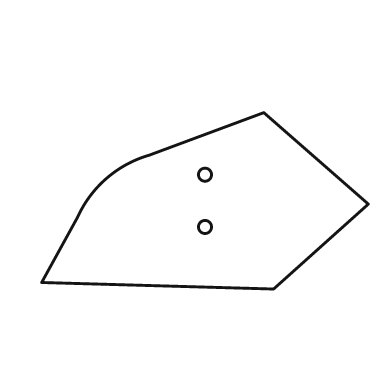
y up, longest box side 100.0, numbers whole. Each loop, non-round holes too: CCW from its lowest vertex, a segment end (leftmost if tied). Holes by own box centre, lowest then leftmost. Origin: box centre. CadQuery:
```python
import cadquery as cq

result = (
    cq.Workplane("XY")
    .moveTo(21.0, -27.0)
    .lineTo(50.0, -1.0)
    .lineTo(18.0, 27.0)
    .lineTo(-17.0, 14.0)
    .threePointArc((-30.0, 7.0), (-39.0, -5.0))
    .lineTo(-50.0, -25.0)
    .close()
    .moveTo(0.0, -8.0)
    .circle(2.0)
    .moveTo(0.0, 8.0)
    .circle(2.0)
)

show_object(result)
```